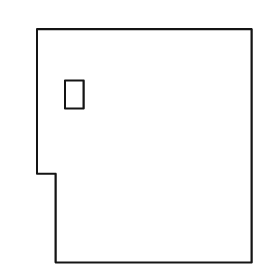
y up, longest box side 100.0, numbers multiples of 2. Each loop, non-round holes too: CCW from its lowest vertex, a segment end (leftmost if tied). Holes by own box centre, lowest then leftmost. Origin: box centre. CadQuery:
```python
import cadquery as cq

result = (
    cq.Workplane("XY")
    .moveTo(-38.0, -50.0)
    .lineTo(46.0, -50.0)
    .lineTo(46.0, 50.0)
    .lineTo(-46.0, 50.0)
    .lineTo(-46.0, -12.0)
    .lineTo(-38.0, -12.0)
    .close()
    .moveTo(-34.0, 16.0)
    .lineTo(-26.0, 16.0)
    .lineTo(-26.0, 28.0)
    .lineTo(-34.0, 28.0)
    .close()
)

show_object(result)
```